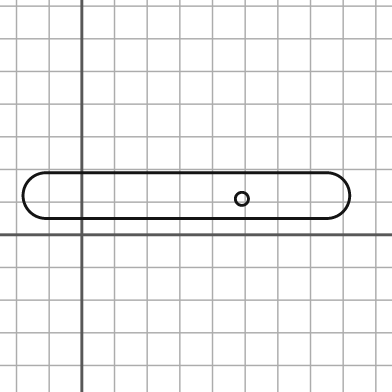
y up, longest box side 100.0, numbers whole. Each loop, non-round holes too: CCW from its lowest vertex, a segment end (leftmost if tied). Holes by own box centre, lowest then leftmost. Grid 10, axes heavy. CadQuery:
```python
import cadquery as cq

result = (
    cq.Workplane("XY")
    .moveTo(-11.0, 5.0)
    .lineTo(75.0, 5.0)
    .threePointArc((82.0, 12.0), (75.0, 19.0))
    .lineTo(-11.0, 19.0)
    .threePointArc((-18.0, 12.0), (-11.0, 5.0))
    .close()
    .moveTo(49.0, 11.0)
    .circle(2.0)
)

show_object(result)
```